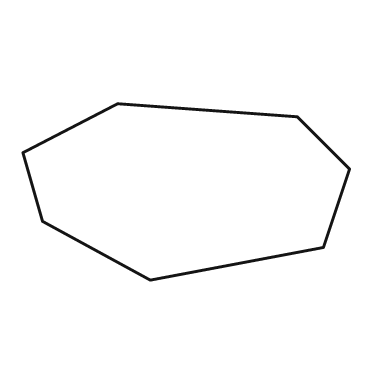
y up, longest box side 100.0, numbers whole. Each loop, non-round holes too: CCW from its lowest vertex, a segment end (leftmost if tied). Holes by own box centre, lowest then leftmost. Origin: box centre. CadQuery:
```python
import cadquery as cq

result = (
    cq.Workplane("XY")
    .moveTo(-11.0, -27.0)
    .lineTo(42.0, -17.0)
    .lineTo(50.0, 7.0)
    .lineTo(34.0, 23.0)
    .lineTo(-21.0, 27.0)
    .lineTo(-50.0, 12.0)
    .lineTo(-44.0, -9.0)
    .close()
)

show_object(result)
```